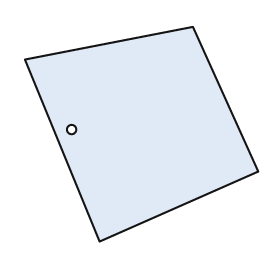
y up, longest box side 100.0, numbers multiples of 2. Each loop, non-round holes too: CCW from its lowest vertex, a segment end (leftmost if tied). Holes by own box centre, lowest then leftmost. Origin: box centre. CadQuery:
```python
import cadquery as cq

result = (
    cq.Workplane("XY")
    .moveTo(-18.0, -46.0)
    .lineTo(50.0, -16.0)
    .lineTo(22.0, 46.0)
    .lineTo(-50.0, 32.0)
    .close()
    .moveTo(-30.0, 2.0)
    .circle(2.0)
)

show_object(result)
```